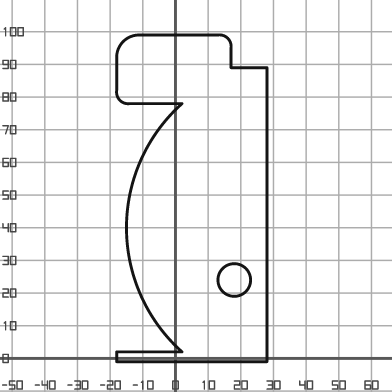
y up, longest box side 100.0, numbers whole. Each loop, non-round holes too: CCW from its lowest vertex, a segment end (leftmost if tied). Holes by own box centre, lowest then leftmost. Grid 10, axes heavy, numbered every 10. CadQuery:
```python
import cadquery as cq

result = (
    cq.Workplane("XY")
    .moveTo(-18.0, -1.0)
    .lineTo(28.0, -1.0)
    .lineTo(28.0, 89.0)
    .lineTo(17.0, 89.0)
    .lineTo(17.0, 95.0)
    .threePointArc((16.0, 98.0), (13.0, 99.0))
    .lineTo(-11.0, 99.0)
    .threePointArc((-16.0, 97.0), (-18.0, 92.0))
    .lineTo(-18.0, 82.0)
    .threePointArc((-17.0, 79.0), (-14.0, 78.0))
    .lineTo(2.0, 78.0)
    .threePointArc((-15.0, 40.0), (2.0, 2.0))
    .lineTo(-18.0, 2.0)
    .close()
    .moveTo(18.0, 24.0)
    .circle(5.0)
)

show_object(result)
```